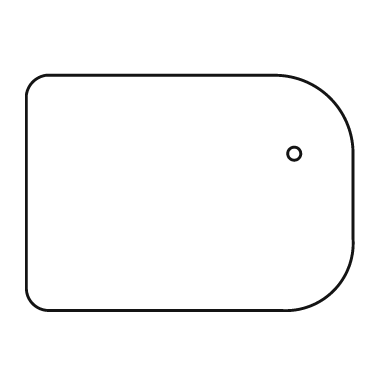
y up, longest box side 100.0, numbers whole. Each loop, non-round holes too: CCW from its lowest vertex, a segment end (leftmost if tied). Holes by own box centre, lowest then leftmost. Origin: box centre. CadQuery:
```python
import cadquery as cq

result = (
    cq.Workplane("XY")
    .moveTo(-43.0, -36.0)
    .lineTo(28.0, -36.0)
    .threePointArc((44.0, -30.0), (50.0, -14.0))
    .lineTo(50.0, 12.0)
    .threePointArc((43.0, 29.0), (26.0, 36.0))
    .lineTo(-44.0, 36.0)
    .threePointArc((-48.0, 34.0), (-50.0, 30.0))
    .lineTo(-50.0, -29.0)
    .threePointArc((-48.0, -34.0), (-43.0, -36.0))
    .close()
    .moveTo(32.0, 12.0)
    .circle(2.0)
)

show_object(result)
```